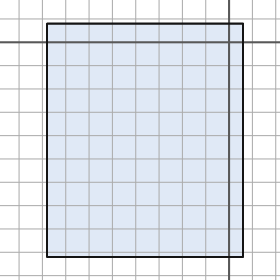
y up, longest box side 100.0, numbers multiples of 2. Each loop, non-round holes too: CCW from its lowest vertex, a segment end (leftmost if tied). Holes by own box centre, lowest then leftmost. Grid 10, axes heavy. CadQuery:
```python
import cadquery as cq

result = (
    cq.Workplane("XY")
    .moveTo(-78.0, -92.0)
    .lineTo(6.0, -92.0)
    .lineTo(6.0, 8.0)
    .lineTo(-78.0, 8.0)
    .close()
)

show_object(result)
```